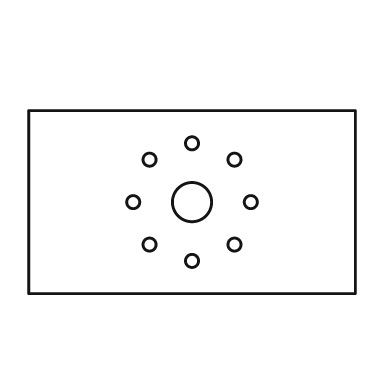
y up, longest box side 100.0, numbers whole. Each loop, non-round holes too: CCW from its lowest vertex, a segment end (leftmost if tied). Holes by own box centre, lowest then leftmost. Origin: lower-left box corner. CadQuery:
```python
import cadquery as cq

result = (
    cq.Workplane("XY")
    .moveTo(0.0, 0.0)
    .lineTo(100.0, 0.0)
    .lineTo(100.0, 56.0)
    .lineTo(0.0, 56.0)
    .close()
    .moveTo(50.0, 10.0)
    .circle(2.0)
    .moveTo(37.0, 15.0)
    .circle(2.0)
    .moveTo(63.0, 15.0)
    .circle(2.0)
    .moveTo(32.0, 28.0)
    .circle(2.0)
    .moveTo(50.0, 28.0)
    .circle(6.0)
    .moveTo(68.0, 28.0)
    .circle(2.0)
    .moveTo(37.0, 41.0)
    .circle(2.0)
    .moveTo(63.0, 41.0)
    .circle(2.0)
    .moveTo(50.0, 46.0)
    .circle(2.0)
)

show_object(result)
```